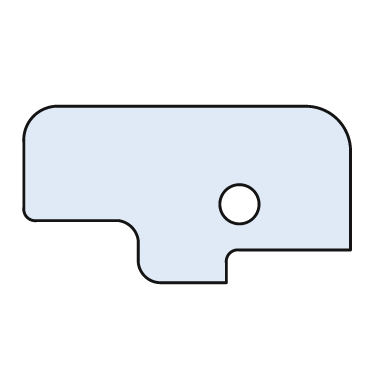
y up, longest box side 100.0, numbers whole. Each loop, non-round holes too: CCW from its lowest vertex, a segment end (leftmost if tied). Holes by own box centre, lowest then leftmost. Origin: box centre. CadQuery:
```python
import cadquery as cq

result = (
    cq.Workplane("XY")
    .moveTo(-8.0, -27.0)
    .lineTo(12.0, -27.0)
    .lineTo(12.0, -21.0)
    .threePointArc((13.0, -18.0), (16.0, -17.0))
    .lineTo(50.0, -17.0)
    .lineTo(50.0, 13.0)
    .threePointArc((46.0, 23.0), (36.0, 27.0))
    .lineTo(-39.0, 27.0)
    .threePointArc((-47.0, 24.0), (-50.0, 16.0))
    .lineTo(-50.0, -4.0)
    .threePointArc((-49.0, -7.0), (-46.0, -8.0))
    .lineTo(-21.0, -8.0)
    .threePointArc((-17.0, -10.0), (-15.0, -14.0))
    .lineTo(-15.0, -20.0)
    .threePointArc((-13.0, -25.0), (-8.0, -27.0))
    .close()
    .moveTo(16.0, -3.0)
    .circle(6.0)
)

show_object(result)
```